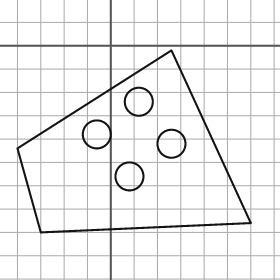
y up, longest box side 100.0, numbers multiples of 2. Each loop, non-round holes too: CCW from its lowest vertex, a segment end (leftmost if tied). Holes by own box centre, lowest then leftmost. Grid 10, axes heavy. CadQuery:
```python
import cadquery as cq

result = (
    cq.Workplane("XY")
    .moveTo(-30.0, -80.0)
    .lineTo(60.0, -76.0)
    .lineTo(26.0, -2.0)
    .lineTo(-40.0, -44.0)
    .close()
    .moveTo(8.0, -56.0)
    .circle(6.0)
    .moveTo(26.0, -42.0)
    .circle(6.0)
    .moveTo(-6.0, -38.0)
    .circle(6.0)
    .moveTo(12.0, -24.0)
    .circle(6.0)
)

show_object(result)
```